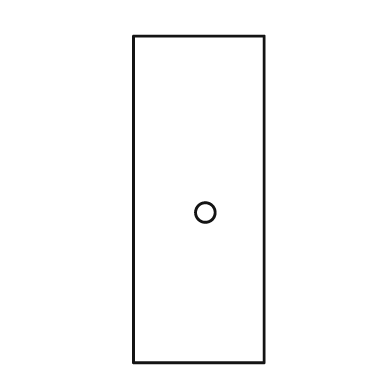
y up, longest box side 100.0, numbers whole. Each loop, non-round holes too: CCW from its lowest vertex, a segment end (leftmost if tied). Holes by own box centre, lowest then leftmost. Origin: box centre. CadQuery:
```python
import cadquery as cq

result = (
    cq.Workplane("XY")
    .moveTo(-20.0, -50.0)
    .lineTo(20.0, -50.0)
    .lineTo(20.0, 50.0)
    .lineTo(-20.0, 50.0)
    .close()
    .moveTo(2.0, -4.0)
    .circle(3.0)
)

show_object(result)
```